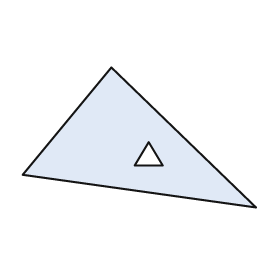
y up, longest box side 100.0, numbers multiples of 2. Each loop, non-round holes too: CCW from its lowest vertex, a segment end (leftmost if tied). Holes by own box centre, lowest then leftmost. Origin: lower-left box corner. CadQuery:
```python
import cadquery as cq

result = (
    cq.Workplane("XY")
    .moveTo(100.0, 0.0)
    .lineTo(38.0, 60.0)
    .lineTo(0.0, 14.0)
    .close()
    .moveTo(48.0, 18.0)
    .lineTo(60.0, 18.0)
    .lineTo(54.0, 28.0)
    .close()
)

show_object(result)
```